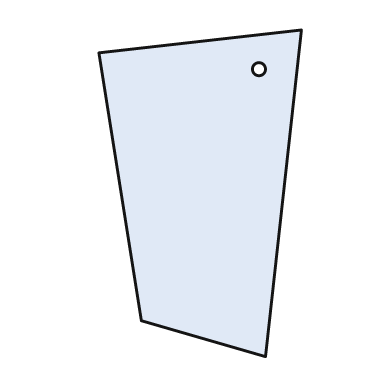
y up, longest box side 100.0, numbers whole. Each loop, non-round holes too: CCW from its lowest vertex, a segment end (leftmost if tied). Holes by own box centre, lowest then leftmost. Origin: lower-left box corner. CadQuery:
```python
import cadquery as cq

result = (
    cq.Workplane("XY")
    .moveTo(51.0, 0.0)
    .lineTo(62.0, 100.0)
    .lineTo(0.0, 93.0)
    .lineTo(13.0, 11.0)
    .close()
    .moveTo(49.0, 88.0)
    .circle(2.0)
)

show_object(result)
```